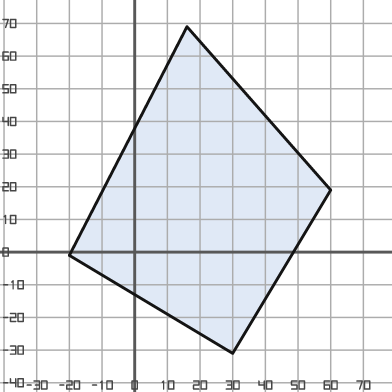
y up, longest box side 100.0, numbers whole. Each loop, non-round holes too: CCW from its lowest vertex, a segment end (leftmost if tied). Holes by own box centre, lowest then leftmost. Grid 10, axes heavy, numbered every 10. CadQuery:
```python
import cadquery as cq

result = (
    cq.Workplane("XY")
    .moveTo(30.0, -31.0)
    .lineTo(60.0, 19.0)
    .lineTo(16.0, 69.0)
    .lineTo(-20.0, -1.0)
    .close()
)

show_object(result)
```